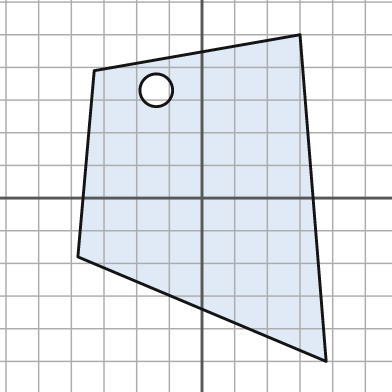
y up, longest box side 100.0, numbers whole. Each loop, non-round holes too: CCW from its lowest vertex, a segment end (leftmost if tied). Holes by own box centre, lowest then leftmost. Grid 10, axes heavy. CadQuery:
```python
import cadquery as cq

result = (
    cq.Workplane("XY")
    .moveTo(38.0, -50.0)
    .lineTo(30.0, 50.0)
    .lineTo(-33.0, 39.0)
    .lineTo(-38.0, -18.0)
    .close()
    .moveTo(-14.0, 33.0)
    .circle(5.0)
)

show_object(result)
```